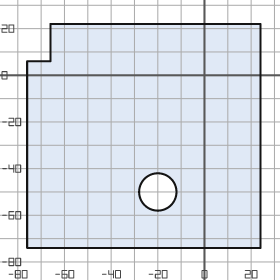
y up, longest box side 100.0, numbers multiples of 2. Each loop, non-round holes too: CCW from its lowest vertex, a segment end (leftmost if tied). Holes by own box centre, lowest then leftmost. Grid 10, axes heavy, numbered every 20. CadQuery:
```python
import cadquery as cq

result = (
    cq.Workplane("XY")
    .moveTo(-76.0, -74.0)
    .lineTo(24.0, -74.0)
    .lineTo(24.0, 22.0)
    .lineTo(-66.0, 22.0)
    .lineTo(-66.0, 6.0)
    .lineTo(-76.0, 6.0)
    .close()
    .moveTo(-20.0, -50.0)
    .circle(8.0)
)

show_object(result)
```